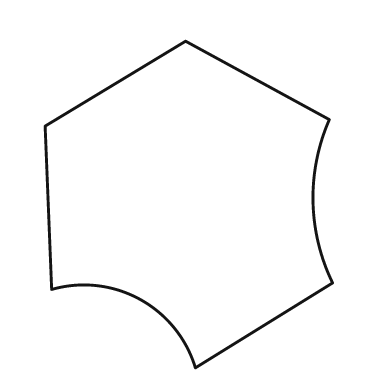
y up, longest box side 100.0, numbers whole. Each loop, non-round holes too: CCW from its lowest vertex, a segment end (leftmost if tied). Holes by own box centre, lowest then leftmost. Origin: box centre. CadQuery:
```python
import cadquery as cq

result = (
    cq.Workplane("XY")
    .moveTo(2.0, -50.0)
    .lineTo(44.0, -24.0)
    .threePointArc((38.0, 1.0), (43.0, 26.0))
    .lineTo(-1.0, 50.0)
    .lineTo(-44.0, 24.0)
    .lineTo(-42.0, -26.0)
    .threePointArc((-15.0, -29.0), (2.0, -50.0))
    .close()
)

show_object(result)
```